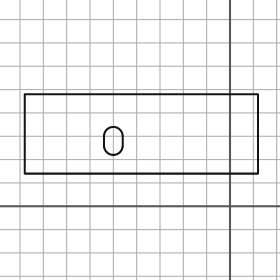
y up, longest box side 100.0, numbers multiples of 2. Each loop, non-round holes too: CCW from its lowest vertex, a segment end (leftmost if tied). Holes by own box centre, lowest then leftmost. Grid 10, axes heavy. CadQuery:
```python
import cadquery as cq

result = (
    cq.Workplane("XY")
    .moveTo(-88.0, 14.0)
    .lineTo(12.0, 14.0)
    .lineTo(12.0, 48.0)
    .lineTo(-88.0, 48.0)
    .close()
    .moveTo(-54.0, 26.0)
    .threePointArc((-50.0, 22.0), (-46.0, 26.0))
    .lineTo(-46.0, 30.0)
    .threePointArc((-50.0, 34.0), (-54.0, 30.0))
    .close()
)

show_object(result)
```